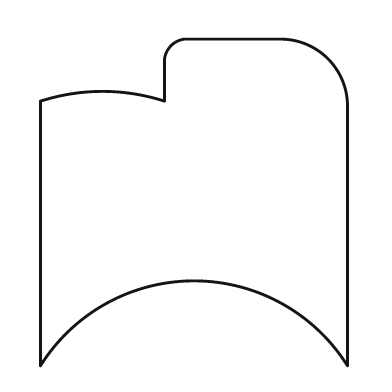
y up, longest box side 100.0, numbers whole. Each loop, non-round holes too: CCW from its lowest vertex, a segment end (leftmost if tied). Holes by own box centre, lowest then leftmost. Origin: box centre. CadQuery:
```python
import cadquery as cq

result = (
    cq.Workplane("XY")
    .moveTo(-47.0, -50.0)
    .threePointArc((0.0, -24.0), (47.0, -50.0))
    .lineTo(47.0, 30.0)
    .threePointArc((41.0, 44.0), (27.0, 50.0))
    .lineTo(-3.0, 50.0)
    .threePointArc((-7.0, 48.0), (-9.0, 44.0))
    .lineTo(-9.0, 31.0)
    .threePointArc((-28.0, 34.0), (-47.0, 31.0))
    .close()
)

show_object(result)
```